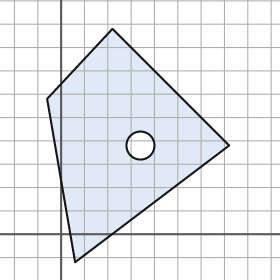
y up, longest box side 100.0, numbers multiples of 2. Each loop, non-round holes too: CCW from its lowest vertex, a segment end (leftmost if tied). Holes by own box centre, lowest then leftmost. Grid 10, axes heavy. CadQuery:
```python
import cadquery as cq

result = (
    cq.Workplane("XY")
    .moveTo(6.0, -12.0)
    .lineTo(72.0, 38.0)
    .lineTo(22.0, 88.0)
    .lineTo(-6.0, 58.0)
    .close()
    .moveTo(34.0, 38.0)
    .circle(6.0)
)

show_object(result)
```